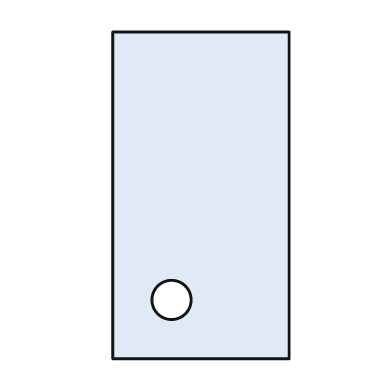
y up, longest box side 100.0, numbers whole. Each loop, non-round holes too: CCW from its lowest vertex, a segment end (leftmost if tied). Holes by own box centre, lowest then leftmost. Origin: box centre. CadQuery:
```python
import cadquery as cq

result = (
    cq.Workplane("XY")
    .moveTo(-27.0, -50.0)
    .lineTo(27.0, -50.0)
    .lineTo(27.0, 50.0)
    .lineTo(-27.0, 50.0)
    .close()
    .moveTo(-9.0, -32.0)
    .circle(6.0)
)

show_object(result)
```